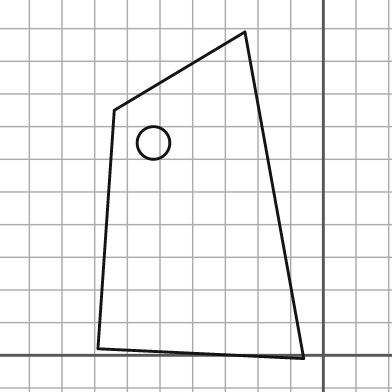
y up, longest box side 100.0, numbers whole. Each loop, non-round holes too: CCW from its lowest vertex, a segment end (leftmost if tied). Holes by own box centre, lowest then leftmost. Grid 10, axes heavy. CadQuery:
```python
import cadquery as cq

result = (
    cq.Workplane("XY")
    .moveTo(-6.0, -1.0)
    .lineTo(-24.0, 99.0)
    .lineTo(-64.0, 75.0)
    .lineTo(-69.0, 2.0)
    .close()
    .moveTo(-52.0, 65.0)
    .circle(5.0)
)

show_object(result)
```